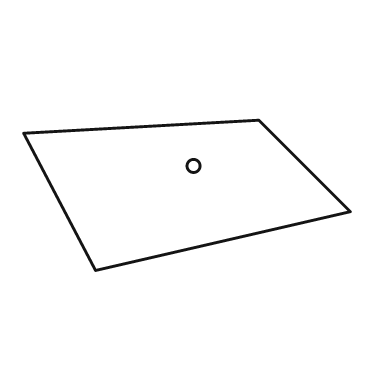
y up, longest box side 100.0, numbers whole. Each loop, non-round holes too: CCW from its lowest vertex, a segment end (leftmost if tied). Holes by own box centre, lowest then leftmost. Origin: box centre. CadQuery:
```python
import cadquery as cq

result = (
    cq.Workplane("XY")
    .moveTo(-28.0, -23.0)
    .lineTo(50.0, -5.0)
    .lineTo(22.0, 23.0)
    .lineTo(-50.0, 19.0)
    .close()
    .moveTo(2.0, 9.0)
    .circle(2.0)
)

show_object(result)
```